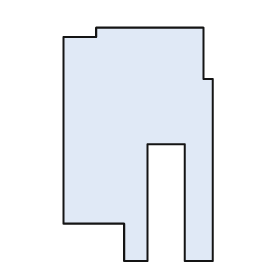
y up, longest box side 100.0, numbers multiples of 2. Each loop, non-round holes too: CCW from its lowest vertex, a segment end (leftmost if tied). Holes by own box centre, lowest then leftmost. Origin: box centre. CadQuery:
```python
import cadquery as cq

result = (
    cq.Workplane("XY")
    .moveTo(-6.0, -50.0)
    .lineTo(4.0, -50.0)
    .lineTo(4.0, 0.0)
    .lineTo(20.0, 0.0)
    .lineTo(20.0, -50.0)
    .lineTo(32.0, -50.0)
    .lineTo(32.0, 28.0)
    .lineTo(28.0, 28.0)
    .lineTo(28.0, 50.0)
    .lineTo(-18.0, 50.0)
    .lineTo(-18.0, 46.0)
    .lineTo(-32.0, 46.0)
    .lineTo(-32.0, -34.0)
    .lineTo(-6.0, -34.0)
    .close()
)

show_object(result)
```